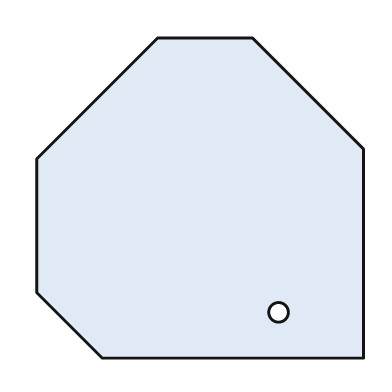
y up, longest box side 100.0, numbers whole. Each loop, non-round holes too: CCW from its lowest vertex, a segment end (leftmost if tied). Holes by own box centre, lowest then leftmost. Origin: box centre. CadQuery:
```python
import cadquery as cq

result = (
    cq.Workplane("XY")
    .moveTo(-30.0, -49.0)
    .lineTo(50.0, -49.0)
    .lineTo(50.0, 15.0)
    .lineTo(16.0, 49.0)
    .lineTo(-13.0, 49.0)
    .lineTo(-50.0, 12.0)
    .lineTo(-50.0, -29.0)
    .close()
    .moveTo(24.0, -35.0)
    .circle(3.0)
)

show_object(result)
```